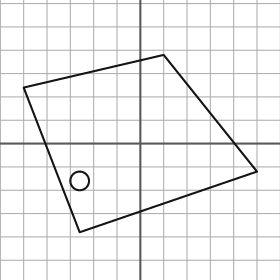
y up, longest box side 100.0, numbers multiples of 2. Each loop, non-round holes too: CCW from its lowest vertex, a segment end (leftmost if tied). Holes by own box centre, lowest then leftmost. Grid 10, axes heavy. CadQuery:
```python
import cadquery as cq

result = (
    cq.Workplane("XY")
    .moveTo(-26.0, -38.0)
    .lineTo(50.0, -12.0)
    .lineTo(10.0, 38.0)
    .lineTo(-50.0, 24.0)
    .close()
    .moveTo(-26.0, -16.0)
    .circle(4.0)
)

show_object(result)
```